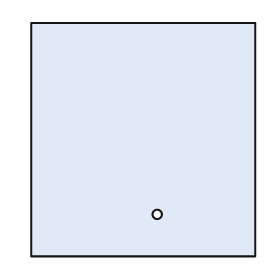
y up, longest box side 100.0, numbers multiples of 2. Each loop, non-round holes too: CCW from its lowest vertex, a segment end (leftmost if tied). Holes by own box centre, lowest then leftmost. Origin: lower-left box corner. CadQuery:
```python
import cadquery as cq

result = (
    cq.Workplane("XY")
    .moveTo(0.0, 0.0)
    .lineTo(96.0, 0.0)
    .lineTo(96.0, 100.0)
    .lineTo(0.0, 100.0)
    .close()
    .moveTo(54.0, 18.0)
    .circle(2.0)
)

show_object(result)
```